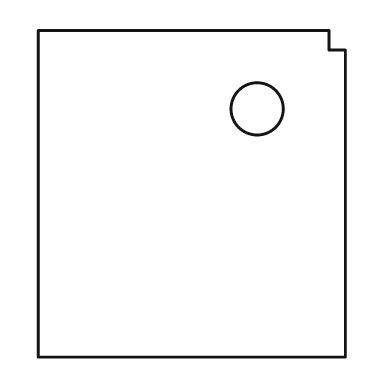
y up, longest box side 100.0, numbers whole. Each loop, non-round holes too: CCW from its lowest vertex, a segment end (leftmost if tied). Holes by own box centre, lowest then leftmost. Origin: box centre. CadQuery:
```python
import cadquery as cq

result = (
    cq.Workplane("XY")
    .moveTo(-47.0, -50.0)
    .lineTo(47.0, -50.0)
    .lineTo(47.0, 44.0)
    .lineTo(42.0, 44.0)
    .lineTo(42.0, 50.0)
    .lineTo(-47.0, 50.0)
    .close()
    .moveTo(20.0, 26.0)
    .circle(8.0)
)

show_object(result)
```